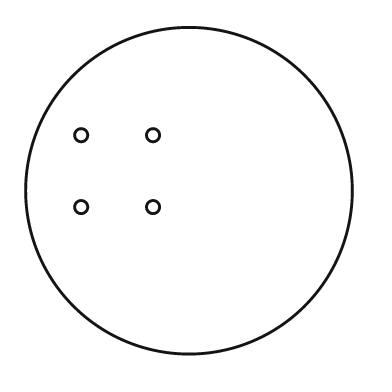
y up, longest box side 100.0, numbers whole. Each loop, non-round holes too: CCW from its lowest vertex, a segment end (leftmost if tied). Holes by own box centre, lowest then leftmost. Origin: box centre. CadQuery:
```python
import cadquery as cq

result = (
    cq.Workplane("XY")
    .moveTo(0.0, 0.0)
    .circle(50.0)
    .moveTo(-33.0, -5.0)
    .circle(2.0)
    .moveTo(-11.0, -5.0)
    .circle(2.0)
    .moveTo(-33.0, 17.0)
    .circle(2.0)
    .moveTo(-11.0, 17.0)
    .circle(2.0)
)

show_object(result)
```